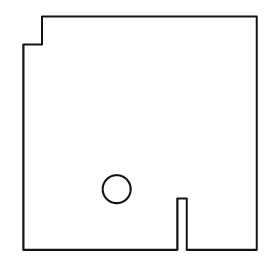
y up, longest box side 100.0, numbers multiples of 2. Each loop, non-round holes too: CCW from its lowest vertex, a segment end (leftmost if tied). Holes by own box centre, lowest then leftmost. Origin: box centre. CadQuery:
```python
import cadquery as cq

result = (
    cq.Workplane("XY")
    .moveTo(-50.0, -50.0)
    .lineTo(16.0, -50.0)
    .lineTo(16.0, -28.0)
    .lineTo(20.0, -28.0)
    .lineTo(20.0, -50.0)
    .lineTo(50.0, -50.0)
    .lineTo(50.0, 50.0)
    .lineTo(-42.0, 50.0)
    .lineTo(-42.0, 38.0)
    .lineTo(-50.0, 38.0)
    .close()
    .moveTo(-10.0, -24.0)
    .circle(6.0)
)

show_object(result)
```